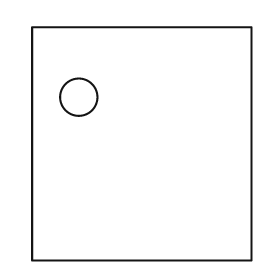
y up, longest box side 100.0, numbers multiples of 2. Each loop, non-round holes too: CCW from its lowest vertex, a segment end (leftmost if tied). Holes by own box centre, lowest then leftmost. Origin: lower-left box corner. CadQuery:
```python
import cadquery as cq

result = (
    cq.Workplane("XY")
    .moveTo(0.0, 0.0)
    .lineTo(94.0, 0.0)
    .lineTo(94.0, 100.0)
    .lineTo(0.0, 100.0)
    .close()
    .moveTo(20.0, 70.0)
    .circle(8.0)
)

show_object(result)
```